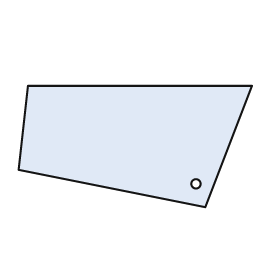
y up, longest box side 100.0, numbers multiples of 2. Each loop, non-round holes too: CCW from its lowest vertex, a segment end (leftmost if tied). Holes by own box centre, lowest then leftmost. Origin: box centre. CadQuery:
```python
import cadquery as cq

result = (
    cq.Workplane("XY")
    .moveTo(30.0, -26.0)
    .lineTo(50.0, 26.0)
    .lineTo(-46.0, 26.0)
    .lineTo(-50.0, -10.0)
    .close()
    .moveTo(26.0, -16.0)
    .circle(2.0)
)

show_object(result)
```